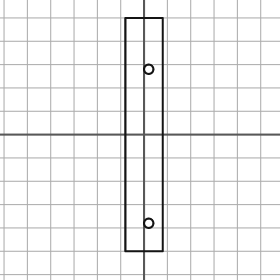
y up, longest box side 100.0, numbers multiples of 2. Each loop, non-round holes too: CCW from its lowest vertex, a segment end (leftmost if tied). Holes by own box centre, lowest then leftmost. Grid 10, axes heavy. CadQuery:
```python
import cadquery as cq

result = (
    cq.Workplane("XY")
    .moveTo(-8.0, -50.0)
    .lineTo(8.0, -50.0)
    .lineTo(8.0, 50.0)
    .lineTo(-8.0, 50.0)
    .close()
    .moveTo(2.0, -38.0)
    .circle(2.0)
    .moveTo(2.0, 28.0)
    .circle(2.0)
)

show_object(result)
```